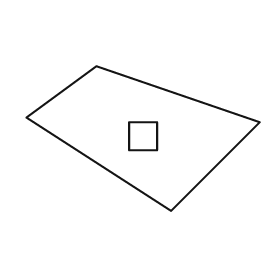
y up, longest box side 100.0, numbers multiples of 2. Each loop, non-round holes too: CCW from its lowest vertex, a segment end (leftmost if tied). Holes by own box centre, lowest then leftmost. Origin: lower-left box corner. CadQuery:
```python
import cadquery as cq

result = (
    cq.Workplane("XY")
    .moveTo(62.0, 0.0)
    .lineTo(100.0, 38.0)
    .lineTo(30.0, 62.0)
    .lineTo(0.0, 40.0)
    .close()
    .moveTo(44.0, 26.0)
    .lineTo(56.0, 26.0)
    .lineTo(56.0, 38.0)
    .lineTo(44.0, 38.0)
    .close()
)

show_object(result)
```